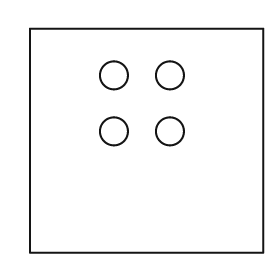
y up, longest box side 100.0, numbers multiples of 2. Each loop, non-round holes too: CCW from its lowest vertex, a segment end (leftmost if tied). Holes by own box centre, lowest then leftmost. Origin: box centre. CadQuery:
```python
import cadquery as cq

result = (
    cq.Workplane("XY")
    .moveTo(-50.0, -48.0)
    .lineTo(50.0, -48.0)
    .lineTo(50.0, 48.0)
    .lineTo(-50.0, 48.0)
    .close()
    .moveTo(-14.0, 4.0)
    .circle(6.0)
    .moveTo(10.0, 4.0)
    .circle(6.0)
    .moveTo(-14.0, 28.0)
    .circle(6.0)
    .moveTo(10.0, 28.0)
    .circle(6.0)
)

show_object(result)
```